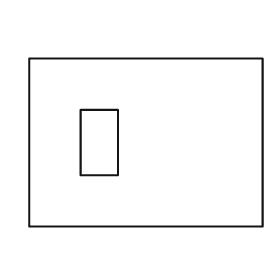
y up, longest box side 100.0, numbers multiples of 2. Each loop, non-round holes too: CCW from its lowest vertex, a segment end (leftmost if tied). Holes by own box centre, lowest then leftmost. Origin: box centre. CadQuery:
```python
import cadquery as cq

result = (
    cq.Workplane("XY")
    .moveTo(-50.0, -36.0)
    .lineTo(50.0, -36.0)
    .lineTo(50.0, 36.0)
    .lineTo(-50.0, 36.0)
    .close()
    .moveTo(-28.0, -14.0)
    .lineTo(-12.0, -14.0)
    .lineTo(-12.0, 14.0)
    .lineTo(-28.0, 14.0)
    .close()
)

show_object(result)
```